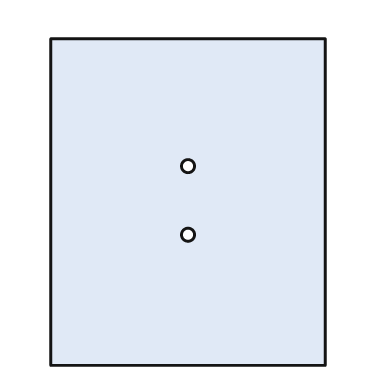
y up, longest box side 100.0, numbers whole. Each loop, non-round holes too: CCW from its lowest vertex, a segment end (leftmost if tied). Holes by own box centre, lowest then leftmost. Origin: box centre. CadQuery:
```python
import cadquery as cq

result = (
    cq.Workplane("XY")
    .moveTo(-42.0, -50.0)
    .lineTo(42.0, -50.0)
    .lineTo(42.0, 50.0)
    .lineTo(-42.0, 50.0)
    .close()
    .moveTo(0.0, -10.0)
    .circle(2.0)
    .moveTo(0.0, 11.0)
    .circle(2.0)
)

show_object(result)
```